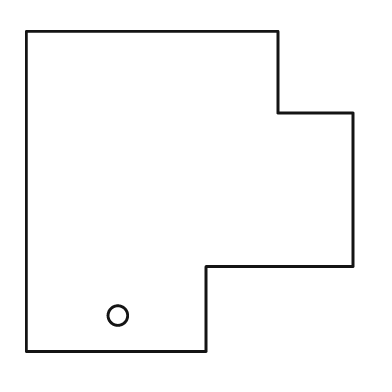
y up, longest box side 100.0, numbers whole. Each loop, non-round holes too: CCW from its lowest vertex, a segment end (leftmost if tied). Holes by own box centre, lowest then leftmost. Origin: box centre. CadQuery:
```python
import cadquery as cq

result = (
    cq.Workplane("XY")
    .moveTo(-50.0, -49.0)
    .lineTo(5.0, -49.0)
    .lineTo(5.0, -23.0)
    .lineTo(50.0, -23.0)
    .lineTo(50.0, 24.0)
    .lineTo(27.0, 24.0)
    .lineTo(27.0, 49.0)
    .lineTo(-50.0, 49.0)
    .close()
    .moveTo(-22.0, -38.0)
    .circle(3.0)
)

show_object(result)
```